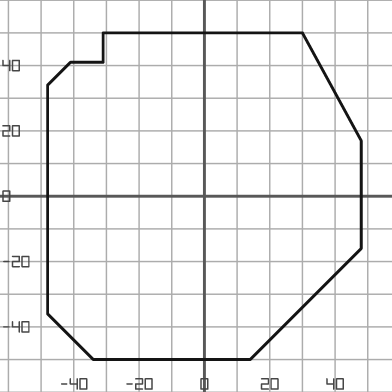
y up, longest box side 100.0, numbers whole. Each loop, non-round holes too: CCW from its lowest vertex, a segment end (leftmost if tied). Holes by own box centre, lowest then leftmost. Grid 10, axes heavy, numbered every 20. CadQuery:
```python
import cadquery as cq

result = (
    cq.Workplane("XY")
    .moveTo(-34.0, -50.0)
    .lineTo(14.0, -50.0)
    .lineTo(48.0, -16.0)
    .lineTo(48.0, 17.0)
    .lineTo(30.0, 50.0)
    .lineTo(-31.0, 50.0)
    .lineTo(-31.0, 41.0)
    .lineTo(-41.0, 41.0)
    .lineTo(-48.0, 34.0)
    .lineTo(-48.0, -36.0)
    .close()
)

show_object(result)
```